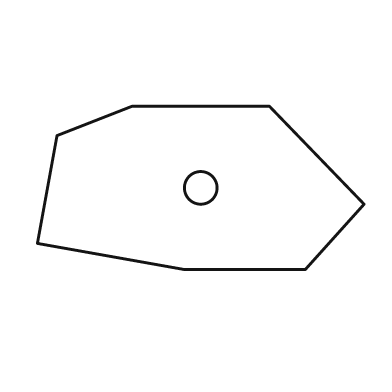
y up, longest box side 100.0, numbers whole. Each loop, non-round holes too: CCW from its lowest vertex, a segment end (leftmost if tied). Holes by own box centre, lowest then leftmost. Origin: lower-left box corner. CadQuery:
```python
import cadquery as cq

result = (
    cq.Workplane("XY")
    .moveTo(45.0, 0.0)
    .lineTo(82.0, 0.0)
    .lineTo(100.0, 20.0)
    .lineTo(71.0, 50.0)
    .lineTo(29.0, 50.0)
    .lineTo(6.0, 41.0)
    .lineTo(0.0, 8.0)
    .close()
    .moveTo(50.0, 25.0)
    .circle(5.0)
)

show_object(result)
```